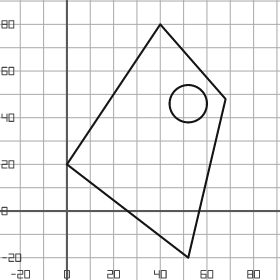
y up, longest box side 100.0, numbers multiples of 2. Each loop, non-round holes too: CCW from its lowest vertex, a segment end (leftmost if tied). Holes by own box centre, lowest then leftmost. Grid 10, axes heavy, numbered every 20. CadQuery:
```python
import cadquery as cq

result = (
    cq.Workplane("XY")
    .moveTo(52.0, -20.0)
    .lineTo(68.0, 48.0)
    .lineTo(40.0, 80.0)
    .lineTo(0.0, 20.0)
    .close()
    .moveTo(52.0, 46.0)
    .circle(8.0)
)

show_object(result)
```